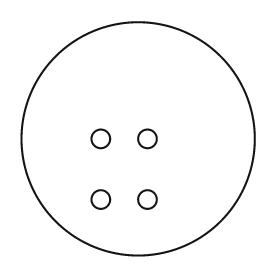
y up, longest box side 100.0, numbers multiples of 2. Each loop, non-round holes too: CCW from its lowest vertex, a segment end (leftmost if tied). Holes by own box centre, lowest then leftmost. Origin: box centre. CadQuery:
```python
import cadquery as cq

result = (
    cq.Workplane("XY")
    .moveTo(0.0, 0.0)
    .circle(50.0)
    .moveTo(-16.0, -26.0)
    .circle(4.0)
    .moveTo(4.0, -26.0)
    .circle(4.0)
    .moveTo(-16.0, 0.0)
    .circle(4.0)
    .moveTo(4.0, 0.0)
    .circle(4.0)
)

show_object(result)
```